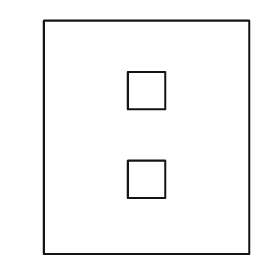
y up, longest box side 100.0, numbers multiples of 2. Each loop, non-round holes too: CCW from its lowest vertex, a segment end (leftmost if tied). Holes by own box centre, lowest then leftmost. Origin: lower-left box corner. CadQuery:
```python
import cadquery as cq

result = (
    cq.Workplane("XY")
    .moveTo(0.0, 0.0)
    .lineTo(88.0, 0.0)
    .lineTo(88.0, 100.0)
    .lineTo(0.0, 100.0)
    .close()
    .moveTo(36.0, 24.0)
    .lineTo(52.0, 24.0)
    .lineTo(52.0, 40.0)
    .lineTo(36.0, 40.0)
    .close()
    .moveTo(36.0, 62.0)
    .lineTo(52.0, 62.0)
    .lineTo(52.0, 78.0)
    .lineTo(36.0, 78.0)
    .close()
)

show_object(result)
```